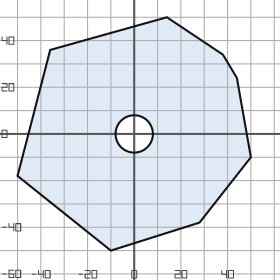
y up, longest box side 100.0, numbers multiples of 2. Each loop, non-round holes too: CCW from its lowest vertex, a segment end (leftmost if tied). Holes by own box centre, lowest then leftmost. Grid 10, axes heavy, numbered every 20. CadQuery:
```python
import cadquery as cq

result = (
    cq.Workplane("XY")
    .moveTo(-10.0, -50.0)
    .lineTo(28.0, -38.0)
    .lineTo(50.0, -10.0)
    .lineTo(44.0, 24.0)
    .lineTo(38.0, 34.0)
    .lineTo(14.0, 50.0)
    .lineTo(-36.0, 36.0)
    .lineTo(-50.0, -18.0)
    .close()
    .moveTo(0.0, 0.0)
    .circle(8.0)
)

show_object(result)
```